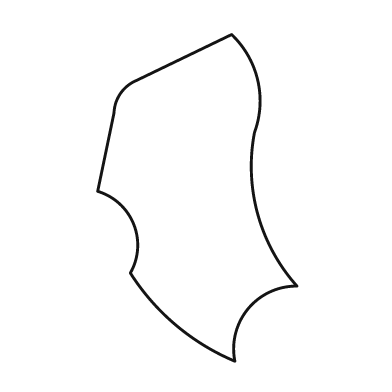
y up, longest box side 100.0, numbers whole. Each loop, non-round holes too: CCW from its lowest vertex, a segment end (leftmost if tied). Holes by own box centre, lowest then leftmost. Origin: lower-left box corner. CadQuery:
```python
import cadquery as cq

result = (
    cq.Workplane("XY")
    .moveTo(42.0, 0.0)
    .threePointArc((46.0, 16.0), (61.0, 23.0))
    .threePointArc((49.0, 45.0), (48.0, 70.0))
    .threePointArc((49.0, 86.0), (41.0, 100.0))
    .lineTo(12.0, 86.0)
    .threePointArc((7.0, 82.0), (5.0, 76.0))
    .lineTo(0.0, 52.0)
    .threePointArc((11.0, 42.0), (10.0, 27.0))
    .threePointArc((24.0, 11.0), (42.0, 0.0))
    .close()
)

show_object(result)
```